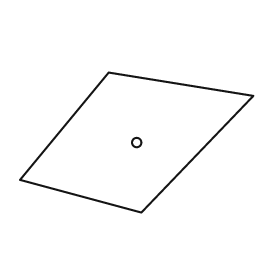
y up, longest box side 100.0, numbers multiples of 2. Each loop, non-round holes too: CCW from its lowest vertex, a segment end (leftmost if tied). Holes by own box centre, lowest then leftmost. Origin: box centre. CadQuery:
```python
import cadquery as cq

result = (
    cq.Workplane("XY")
    .moveTo(2.0, -30.0)
    .lineTo(50.0, 20.0)
    .lineTo(-12.0, 30.0)
    .lineTo(-50.0, -16.0)
    .close()
    .moveTo(0.0, 0.0)
    .circle(2.0)
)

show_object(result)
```